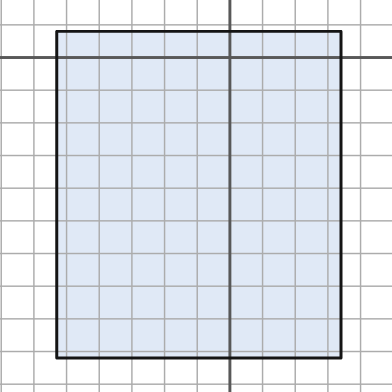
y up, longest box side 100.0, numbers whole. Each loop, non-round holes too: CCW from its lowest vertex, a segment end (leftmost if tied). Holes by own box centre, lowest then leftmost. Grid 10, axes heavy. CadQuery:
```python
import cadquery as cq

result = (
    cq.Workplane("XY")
    .moveTo(-53.0, -92.0)
    .lineTo(34.0, -92.0)
    .lineTo(34.0, 8.0)
    .lineTo(-53.0, 8.0)
    .close()
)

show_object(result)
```